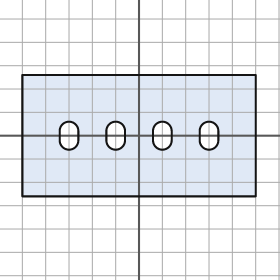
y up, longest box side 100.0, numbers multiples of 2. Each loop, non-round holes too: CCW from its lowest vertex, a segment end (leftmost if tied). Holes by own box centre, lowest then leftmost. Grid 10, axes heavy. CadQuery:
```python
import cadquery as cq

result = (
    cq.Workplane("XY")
    .moveTo(-50.0, -26.0)
    .lineTo(50.0, -26.0)
    .lineTo(50.0, 26.0)
    .lineTo(-50.0, 26.0)
    .close()
    .moveTo(-34.0, -2.0)
    .threePointArc((-30.0, -6.0), (-26.0, -2.0))
    .lineTo(-26.0, 2.0)
    .threePointArc((-30.0, 6.0), (-34.0, 2.0))
    .close()
    .moveTo(-14.0, -2.0)
    .threePointArc((-10.0, -6.0), (-6.0, -2.0))
    .lineTo(-6.0, 2.0)
    .threePointArc((-10.0, 6.0), (-14.0, 2.0))
    .close()
    .moveTo(6.0, -2.0)
    .threePointArc((10.0, -6.0), (14.0, -2.0))
    .lineTo(14.0, 2.0)
    .threePointArc((10.0, 6.0), (6.0, 2.0))
    .close()
    .moveTo(26.0, -2.0)
    .threePointArc((30.0, -6.0), (34.0, -2.0))
    .lineTo(34.0, 2.0)
    .threePointArc((30.0, 6.0), (26.0, 2.0))
    .close()
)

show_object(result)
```